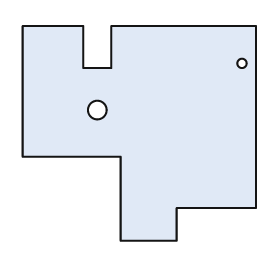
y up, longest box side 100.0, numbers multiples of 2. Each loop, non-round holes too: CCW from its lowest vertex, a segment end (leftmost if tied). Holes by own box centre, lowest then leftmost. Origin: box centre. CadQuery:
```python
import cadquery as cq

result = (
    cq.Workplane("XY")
    .moveTo(-8.0, -46.0)
    .lineTo(16.0, -46.0)
    .lineTo(16.0, -32.0)
    .lineTo(50.0, -32.0)
    .lineTo(50.0, 46.0)
    .lineTo(-12.0, 46.0)
    .lineTo(-12.0, 28.0)
    .lineTo(-24.0, 28.0)
    .lineTo(-24.0, 46.0)
    .lineTo(-50.0, 46.0)
    .lineTo(-50.0, -10.0)
    .lineTo(-8.0, -10.0)
    .close()
    .moveTo(-18.0, 10.0)
    .circle(4.0)
    .moveTo(44.0, 30.0)
    .circle(2.0)
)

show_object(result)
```